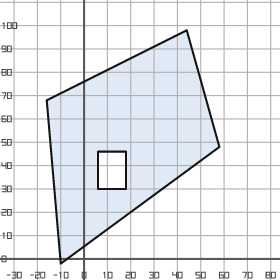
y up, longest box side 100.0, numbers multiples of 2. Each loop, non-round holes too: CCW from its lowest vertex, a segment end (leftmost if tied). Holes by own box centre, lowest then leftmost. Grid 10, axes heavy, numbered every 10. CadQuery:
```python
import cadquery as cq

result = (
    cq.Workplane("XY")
    .moveTo(-10.0, -2.0)
    .lineTo(58.0, 48.0)
    .lineTo(44.0, 98.0)
    .lineTo(-16.0, 68.0)
    .close()
    .moveTo(6.0, 30.0)
    .lineTo(18.0, 30.0)
    .lineTo(18.0, 46.0)
    .lineTo(6.0, 46.0)
    .close()
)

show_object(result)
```